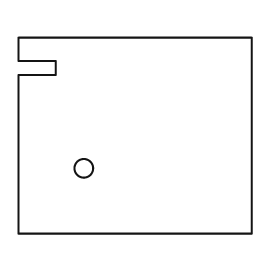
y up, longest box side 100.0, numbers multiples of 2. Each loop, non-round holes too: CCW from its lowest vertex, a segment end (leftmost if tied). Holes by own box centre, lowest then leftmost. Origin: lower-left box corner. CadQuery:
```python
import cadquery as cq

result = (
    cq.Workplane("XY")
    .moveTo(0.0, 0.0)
    .lineTo(100.0, 0.0)
    .lineTo(100.0, 84.0)
    .lineTo(0.0, 84.0)
    .lineTo(0.0, 74.0)
    .lineTo(16.0, 74.0)
    .lineTo(16.0, 68.0)
    .lineTo(0.0, 68.0)
    .close()
    .moveTo(28.0, 28.0)
    .circle(4.0)
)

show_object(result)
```